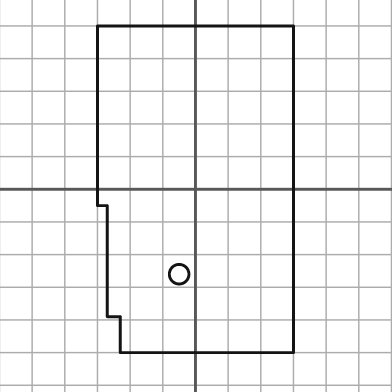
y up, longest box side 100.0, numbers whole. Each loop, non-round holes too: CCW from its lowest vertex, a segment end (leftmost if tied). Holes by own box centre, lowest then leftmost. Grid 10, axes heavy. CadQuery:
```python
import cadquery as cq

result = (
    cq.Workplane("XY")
    .moveTo(-23.0, -50.0)
    .lineTo(30.0, -50.0)
    .lineTo(30.0, 50.0)
    .lineTo(-30.0, 50.0)
    .lineTo(-30.0, -5.0)
    .lineTo(-27.0, -5.0)
    .lineTo(-27.0, -39.0)
    .lineTo(-23.0, -39.0)
    .close()
    .moveTo(-5.0, -26.0)
    .circle(3.0)
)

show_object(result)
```